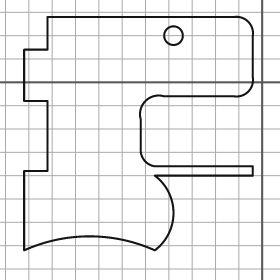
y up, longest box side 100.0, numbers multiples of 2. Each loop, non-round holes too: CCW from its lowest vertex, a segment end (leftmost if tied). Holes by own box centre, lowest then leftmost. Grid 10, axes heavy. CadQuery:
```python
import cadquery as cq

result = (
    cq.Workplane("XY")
    .moveTo(-102.0, -72.0)
    .threePointArc((-74.0, -66.0), (-46.0, -72.0))
    .threePointArc((-38.0, -56.0), (-46.0, -40.0))
    .lineTo(-4.0, -40.0)
    .lineTo(-4.0, -36.0)
    .lineTo(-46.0, -36.0)
    .threePointArc((-50.0, -34.0), (-52.0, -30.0))
    .lineTo(-52.0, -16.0)
    .threePointArc((-50.0, -8.0), (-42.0, -6.0))
    .lineTo(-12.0, -6.0)
    .threePointArc((-6.0, -4.0), (-4.0, 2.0))
    .lineTo(-4.0, 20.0)
    .threePointArc((-6.0, 26.0), (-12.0, 28.0))
    .lineTo(-92.0, 28.0)
    .lineTo(-92.0, 14.0)
    .lineTo(-102.0, 14.0)
    .lineTo(-102.0, -8.0)
    .lineTo(-92.0, -8.0)
    .lineTo(-92.0, -38.0)
    .lineTo(-102.0, -38.0)
    .close()
    .moveTo(-38.0, 20.0)
    .circle(4.0)
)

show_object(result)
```